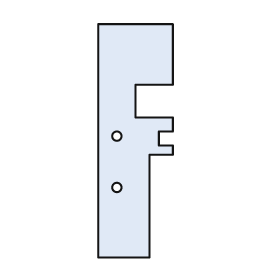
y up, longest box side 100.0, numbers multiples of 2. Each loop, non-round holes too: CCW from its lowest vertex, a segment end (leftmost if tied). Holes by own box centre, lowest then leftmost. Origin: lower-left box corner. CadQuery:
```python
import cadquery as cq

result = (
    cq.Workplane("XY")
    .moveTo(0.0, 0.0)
    .lineTo(22.0, 0.0)
    .lineTo(22.0, 44.0)
    .lineTo(32.0, 44.0)
    .lineTo(32.0, 48.0)
    .lineTo(26.0, 48.0)
    .lineTo(26.0, 54.0)
    .lineTo(32.0, 54.0)
    .lineTo(32.0, 60.0)
    .lineTo(16.0, 60.0)
    .lineTo(16.0, 74.0)
    .lineTo(32.0, 74.0)
    .lineTo(32.0, 100.0)
    .lineTo(0.0, 100.0)
    .close()
    .moveTo(8.0, 30.0)
    .circle(2.0)
    .moveTo(8.0, 52.0)
    .circle(2.0)
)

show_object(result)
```